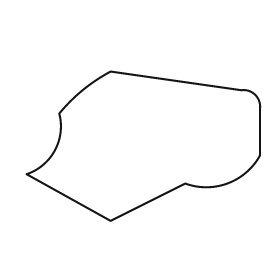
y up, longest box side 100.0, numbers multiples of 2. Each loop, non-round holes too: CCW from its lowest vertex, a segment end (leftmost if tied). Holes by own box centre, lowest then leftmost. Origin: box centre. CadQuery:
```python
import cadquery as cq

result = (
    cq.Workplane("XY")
    .moveTo(-14.0, -32.0)
    .lineTo(18.0, -16.0)
    .threePointArc((36.0, -16.0), (50.0, -4.0))
    .lineTo(50.0, 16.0)
    .threePointArc((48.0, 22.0), (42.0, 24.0))
    .lineTo(-14.0, 32.0)
    .threePointArc((-26.0, 24.0), (-36.0, 14.0))
    .threePointArc((-38.0, -2.0), (-50.0, -12.0))
    .close()
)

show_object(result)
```